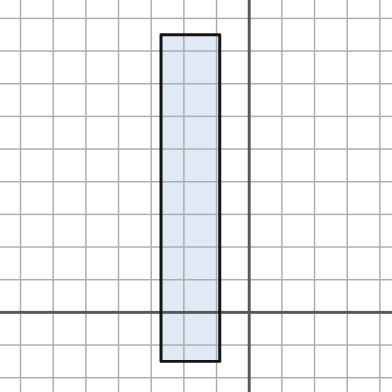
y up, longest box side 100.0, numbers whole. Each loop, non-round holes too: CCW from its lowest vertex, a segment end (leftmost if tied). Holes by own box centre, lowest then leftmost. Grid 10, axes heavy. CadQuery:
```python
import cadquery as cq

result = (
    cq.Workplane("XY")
    .moveTo(-27.0, -15.0)
    .lineTo(-9.0, -15.0)
    .lineTo(-9.0, 85.0)
    .lineTo(-27.0, 85.0)
    .close()
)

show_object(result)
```